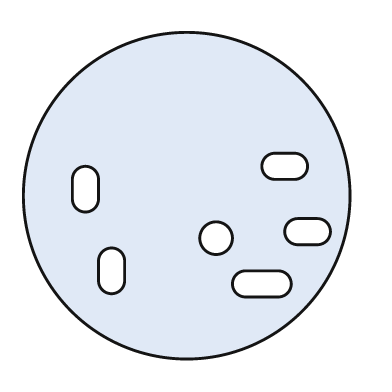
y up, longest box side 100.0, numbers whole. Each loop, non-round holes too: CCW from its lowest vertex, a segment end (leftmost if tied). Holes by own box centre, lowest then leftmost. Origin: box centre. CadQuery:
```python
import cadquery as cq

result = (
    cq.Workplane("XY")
    .moveTo(0.0, 0.0)
    .circle(50.0)
    .moveTo(18.0, -31.0)
    .lineTo(28.0, -31.0)
    .threePointArc((32.0, -27.0), (28.0, -23.0))
    .lineTo(18.0, -23.0)
    .threePointArc((14.0, -27.0), (18.0, -31.0))
    .close()
    .moveTo(-27.0, -26.0)
    .threePointArc((-23.0, -30.0), (-19.0, -26.0))
    .lineTo(-19.0, -20.0)
    .threePointArc((-23.0, -16.0), (-27.0, -20.0))
    .close()
    .moveTo(9.0, -13.0)
    .circle(5.0)
    .moveTo(34.0, -15.0)
    .lineTo(40.0, -15.0)
    .threePointArc((44.0, -11.0), (40.0, -7.0))
    .lineTo(34.0, -7.0)
    .threePointArc((30.0, -11.0), (34.0, -15.0))
    .close()
    .moveTo(-35.0, -1.0)
    .threePointArc((-31.0, -5.0), (-27.0, -1.0))
    .lineTo(-27.0, 5.0)
    .threePointArc((-31.0, 9.0), (-35.0, 5.0))
    .close()
    .moveTo(27.0, 5.0)
    .lineTo(33.0, 5.0)
    .threePointArc((37.0, 9.0), (33.0, 13.0))
    .lineTo(27.0, 13.0)
    .threePointArc((23.0, 9.0), (27.0, 5.0))
    .close()
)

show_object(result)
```